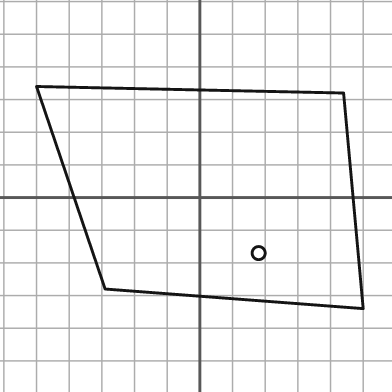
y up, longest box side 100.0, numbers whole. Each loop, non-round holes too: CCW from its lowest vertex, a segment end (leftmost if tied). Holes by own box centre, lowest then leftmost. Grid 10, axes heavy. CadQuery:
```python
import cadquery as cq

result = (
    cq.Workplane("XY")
    .moveTo(50.0, -34.0)
    .lineTo(44.0, 32.0)
    .lineTo(-50.0, 34.0)
    .lineTo(-29.0, -28.0)
    .close()
    .moveTo(18.0, -17.0)
    .circle(2.0)
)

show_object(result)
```